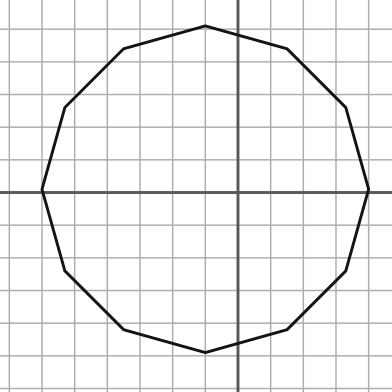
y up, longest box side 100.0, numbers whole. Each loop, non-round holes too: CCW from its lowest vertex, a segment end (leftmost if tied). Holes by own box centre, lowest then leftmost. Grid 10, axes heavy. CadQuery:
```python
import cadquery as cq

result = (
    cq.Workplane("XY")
    .moveTo(-10.0, -49.0)
    .lineTo(15.0, -42.0)
    .lineTo(33.0, -24.0)
    .lineTo(40.0, 1.0)
    .lineTo(33.0, 26.0)
    .lineTo(15.0, 44.0)
    .lineTo(-10.0, 51.0)
    .lineTo(-35.0, 44.0)
    .lineTo(-53.0, 26.0)
    .lineTo(-60.0, 1.0)
    .lineTo(-53.0, -24.0)
    .lineTo(-35.0, -42.0)
    .close()
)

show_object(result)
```